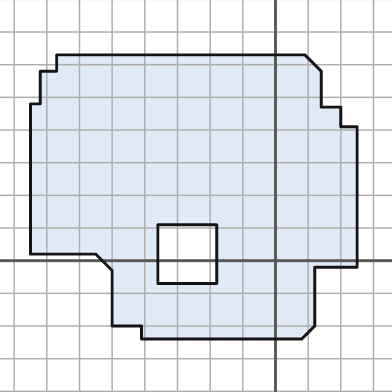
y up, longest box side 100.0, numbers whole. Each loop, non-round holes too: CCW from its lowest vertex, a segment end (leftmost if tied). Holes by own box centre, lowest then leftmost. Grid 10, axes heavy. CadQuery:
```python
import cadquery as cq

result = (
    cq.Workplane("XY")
    .moveTo(-41.0, -24.0)
    .lineTo(8.0, -24.0)
    .lineTo(12.0, -20.0)
    .lineTo(12.0, -2.0)
    .lineTo(25.0, -2.0)
    .lineTo(25.0, 41.0)
    .lineTo(20.0, 41.0)
    .lineTo(20.0, 47.0)
    .lineTo(14.0, 47.0)
    .lineTo(14.0, 58.0)
    .lineTo(9.0, 63.0)
    .lineTo(-67.0, 63.0)
    .lineTo(-67.0, 58.0)
    .lineTo(-72.0, 58.0)
    .lineTo(-72.0, 48.0)
    .lineTo(-75.0, 48.0)
    .lineTo(-75.0, 2.0)
    .lineTo(-55.0, 2.0)
    .lineTo(-50.0, -3.0)
    .lineTo(-50.0, -20.0)
    .lineTo(-41.0, -20.0)
    .close()
    .moveTo(-36.0, -7.0)
    .lineTo(-18.0, -7.0)
    .lineTo(-18.0, 11.0)
    .lineTo(-36.0, 11.0)
    .close()
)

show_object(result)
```